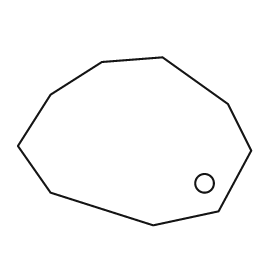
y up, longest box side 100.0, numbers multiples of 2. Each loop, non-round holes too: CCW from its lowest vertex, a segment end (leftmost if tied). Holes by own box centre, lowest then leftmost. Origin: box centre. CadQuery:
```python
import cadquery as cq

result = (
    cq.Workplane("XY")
    .moveTo(8.0, -36.0)
    .lineTo(36.0, -30.0)
    .lineTo(50.0, -4.0)
    .lineTo(40.0, 16.0)
    .lineTo(12.0, 36.0)
    .lineTo(-14.0, 34.0)
    .lineTo(-36.0, 20.0)
    .lineTo(-50.0, -2.0)
    .lineTo(-36.0, -22.0)
    .close()
    .moveTo(30.0, -18.0)
    .circle(4.0)
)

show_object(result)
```